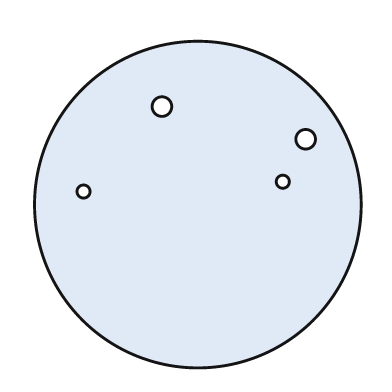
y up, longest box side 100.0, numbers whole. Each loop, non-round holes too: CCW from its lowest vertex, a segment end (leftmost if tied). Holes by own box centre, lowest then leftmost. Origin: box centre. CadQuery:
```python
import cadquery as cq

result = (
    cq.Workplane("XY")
    .moveTo(0.0, 0.0)
    .circle(50.0)
    .moveTo(-35.0, 4.0)
    .circle(2.0)
    .moveTo(26.0, 7.0)
    .circle(2.0)
    .moveTo(33.0, 20.0)
    .circle(3.0)
    .moveTo(-11.0, 30.0)
    .circle(3.0)
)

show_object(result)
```